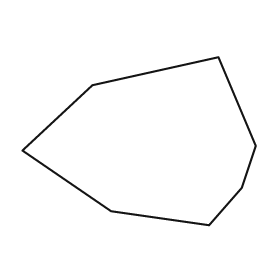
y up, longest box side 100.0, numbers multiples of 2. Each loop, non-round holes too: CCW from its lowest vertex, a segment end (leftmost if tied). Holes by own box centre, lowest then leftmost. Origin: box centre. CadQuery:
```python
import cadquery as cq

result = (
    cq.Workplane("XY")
    .moveTo(30.0, -36.0)
    .lineTo(44.0, -20.0)
    .lineTo(50.0, -2.0)
    .lineTo(34.0, 36.0)
    .lineTo(-20.0, 24.0)
    .lineTo(-50.0, -4.0)
    .lineTo(-12.0, -30.0)
    .close()
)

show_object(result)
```